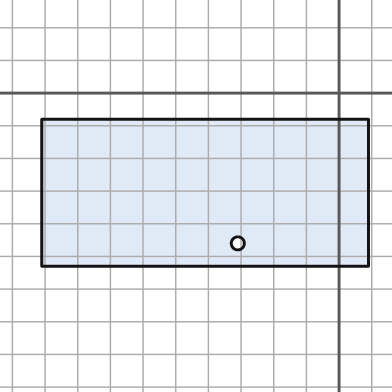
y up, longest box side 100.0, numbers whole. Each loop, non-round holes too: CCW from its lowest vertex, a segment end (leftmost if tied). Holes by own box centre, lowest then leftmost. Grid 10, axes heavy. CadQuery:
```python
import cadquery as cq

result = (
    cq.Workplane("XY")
    .moveTo(-91.0, -53.0)
    .lineTo(9.0, -53.0)
    .lineTo(9.0, -8.0)
    .lineTo(-91.0, -8.0)
    .close()
    .moveTo(-31.0, -46.0)
    .circle(2.0)
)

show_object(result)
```